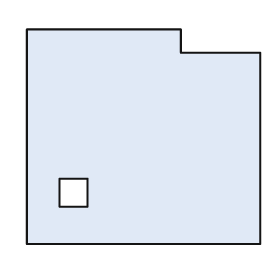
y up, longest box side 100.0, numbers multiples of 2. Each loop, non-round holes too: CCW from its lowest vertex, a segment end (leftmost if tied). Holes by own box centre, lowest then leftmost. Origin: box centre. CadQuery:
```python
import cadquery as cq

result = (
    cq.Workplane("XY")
    .moveTo(-50.0, -46.0)
    .lineTo(50.0, -46.0)
    .lineTo(50.0, 36.0)
    .lineTo(16.0, 36.0)
    .lineTo(16.0, 46.0)
    .lineTo(-50.0, 46.0)
    .close()
    .moveTo(-36.0, -30.0)
    .lineTo(-24.0, -30.0)
    .lineTo(-24.0, -18.0)
    .lineTo(-36.0, -18.0)
    .close()
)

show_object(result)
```